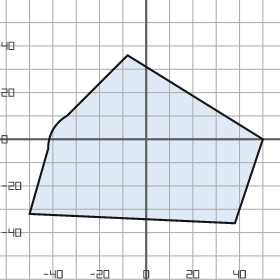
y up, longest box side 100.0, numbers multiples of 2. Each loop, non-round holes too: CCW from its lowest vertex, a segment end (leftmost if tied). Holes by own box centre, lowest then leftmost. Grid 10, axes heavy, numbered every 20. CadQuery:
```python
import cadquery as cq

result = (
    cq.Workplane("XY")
    .moveTo(38.0, -36.0)
    .lineTo(50.0, 0.0)
    .lineTo(-8.0, 36.0)
    .lineTo(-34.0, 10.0)
    .threePointArc((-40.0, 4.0), (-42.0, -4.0))
    .lineTo(-50.0, -32.0)
    .close()
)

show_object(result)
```